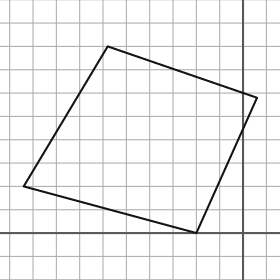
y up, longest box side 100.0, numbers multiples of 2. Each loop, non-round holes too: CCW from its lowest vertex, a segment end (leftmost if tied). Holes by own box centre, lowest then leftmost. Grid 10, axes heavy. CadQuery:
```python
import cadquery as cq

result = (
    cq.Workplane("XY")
    .moveTo(-20.0, 0.0)
    .lineTo(6.0, 58.0)
    .lineTo(-58.0, 80.0)
    .lineTo(-94.0, 20.0)
    .close()
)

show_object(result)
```